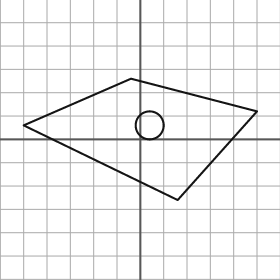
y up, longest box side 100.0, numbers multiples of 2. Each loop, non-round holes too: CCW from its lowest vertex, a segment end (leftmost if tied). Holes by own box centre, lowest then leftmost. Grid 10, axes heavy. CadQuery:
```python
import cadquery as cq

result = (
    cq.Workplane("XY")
    .moveTo(16.0, -26.0)
    .lineTo(50.0, 12.0)
    .lineTo(-4.0, 26.0)
    .lineTo(-50.0, 6.0)
    .close()
    .moveTo(4.0, 6.0)
    .circle(6.0)
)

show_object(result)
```